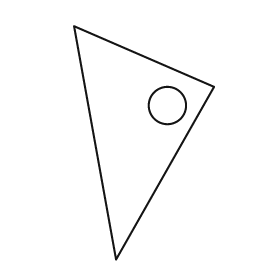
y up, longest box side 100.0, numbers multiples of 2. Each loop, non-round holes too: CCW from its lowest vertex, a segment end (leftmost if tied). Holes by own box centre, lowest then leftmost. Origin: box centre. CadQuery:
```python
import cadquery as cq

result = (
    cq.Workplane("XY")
    .moveTo(-12.0, -50.0)
    .lineTo(30.0, 24.0)
    .lineTo(-30.0, 50.0)
    .close()
    .moveTo(10.0, 16.0)
    .circle(8.0)
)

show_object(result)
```